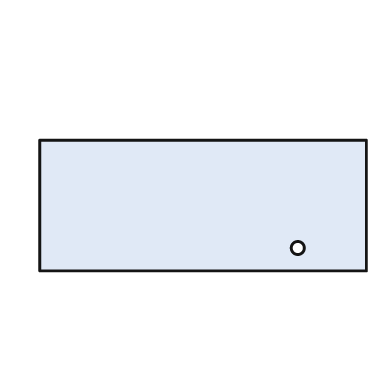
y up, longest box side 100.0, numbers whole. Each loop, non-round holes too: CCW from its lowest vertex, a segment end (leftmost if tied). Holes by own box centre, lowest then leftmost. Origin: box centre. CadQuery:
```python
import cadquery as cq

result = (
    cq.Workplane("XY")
    .moveTo(-50.0, -20.0)
    .lineTo(50.0, -20.0)
    .lineTo(50.0, 20.0)
    .lineTo(-50.0, 20.0)
    .close()
    .moveTo(29.0, -13.0)
    .circle(2.0)
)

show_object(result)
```